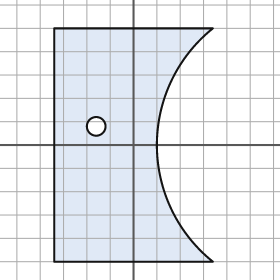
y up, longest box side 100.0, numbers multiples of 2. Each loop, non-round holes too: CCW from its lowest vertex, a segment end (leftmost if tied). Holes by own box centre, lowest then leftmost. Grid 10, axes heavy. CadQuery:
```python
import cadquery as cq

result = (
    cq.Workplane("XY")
    .moveTo(-34.0, -50.0)
    .lineTo(34.0, -50.0)
    .threePointArc((10.0, 0.0), (34.0, 50.0))
    .lineTo(-34.0, 50.0)
    .close()
    .moveTo(-16.0, 8.0)
    .circle(4.0)
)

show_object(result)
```